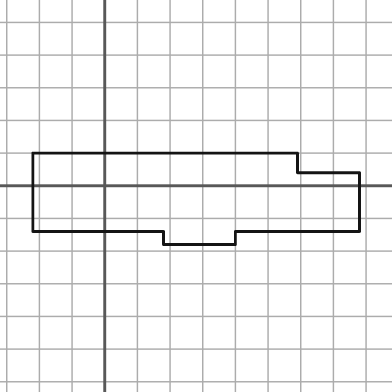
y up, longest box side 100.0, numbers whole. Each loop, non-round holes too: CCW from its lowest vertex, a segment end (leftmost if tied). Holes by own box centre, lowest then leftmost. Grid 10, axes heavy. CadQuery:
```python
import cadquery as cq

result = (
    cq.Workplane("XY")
    .moveTo(18.0, -18.0)
    .lineTo(40.0, -18.0)
    .lineTo(40.0, -14.0)
    .lineTo(78.0, -14.0)
    .lineTo(78.0, 4.0)
    .lineTo(59.0, 4.0)
    .lineTo(59.0, 10.0)
    .lineTo(-22.0, 10.0)
    .lineTo(-22.0, -14.0)
    .lineTo(18.0, -14.0)
    .close()
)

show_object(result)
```